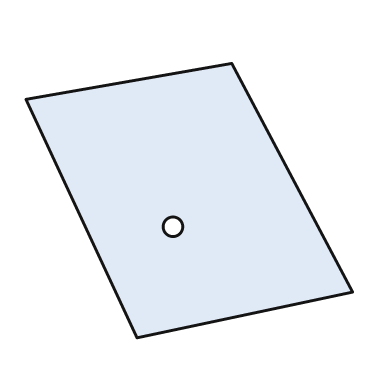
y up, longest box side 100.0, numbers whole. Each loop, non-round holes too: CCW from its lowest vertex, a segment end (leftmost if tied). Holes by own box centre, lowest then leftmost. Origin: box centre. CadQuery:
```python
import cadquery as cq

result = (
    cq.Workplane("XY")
    .moveTo(-16.0, -42.0)
    .lineTo(50.0, -28.0)
    .lineTo(13.0, 42.0)
    .lineTo(-50.0, 31.0)
    .close()
    .moveTo(-5.0, -8.0)
    .circle(3.0)
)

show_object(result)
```